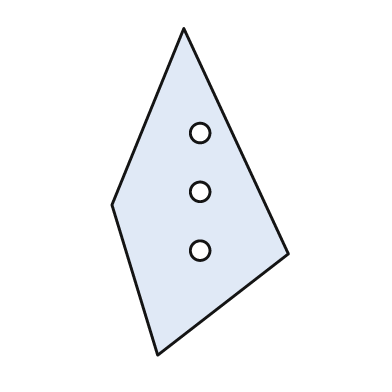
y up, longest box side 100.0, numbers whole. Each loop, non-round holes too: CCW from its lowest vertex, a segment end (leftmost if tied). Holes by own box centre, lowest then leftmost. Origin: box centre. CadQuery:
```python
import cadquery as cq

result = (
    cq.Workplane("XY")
    .moveTo(-13.0, -50.0)
    .lineTo(27.0, -19.0)
    .lineTo(-5.0, 50.0)
    .lineTo(-27.0, -4.0)
    .close()
    .moveTo(0.0, -18.0)
    .circle(3.0)
    .moveTo(0.0, 0.0)
    .circle(3.0)
    .moveTo(0.0, 18.0)
    .circle(3.0)
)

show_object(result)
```